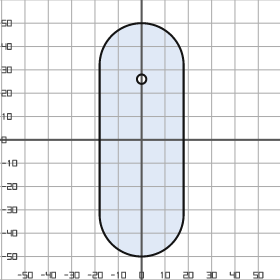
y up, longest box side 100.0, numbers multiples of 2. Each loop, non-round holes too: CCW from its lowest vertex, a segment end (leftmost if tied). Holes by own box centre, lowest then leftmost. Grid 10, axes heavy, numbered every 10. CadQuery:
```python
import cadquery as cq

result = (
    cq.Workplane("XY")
    .moveTo(-18.0, -32.0)
    .threePointArc((0.0, -50.0), (18.0, -32.0))
    .lineTo(18.0, 32.0)
    .threePointArc((0.0, 50.0), (-18.0, 32.0))
    .close()
    .moveTo(0.0, 26.0)
    .circle(2.0)
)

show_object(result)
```